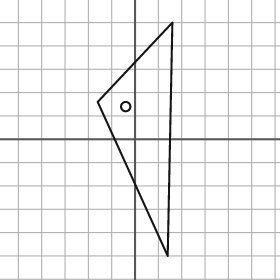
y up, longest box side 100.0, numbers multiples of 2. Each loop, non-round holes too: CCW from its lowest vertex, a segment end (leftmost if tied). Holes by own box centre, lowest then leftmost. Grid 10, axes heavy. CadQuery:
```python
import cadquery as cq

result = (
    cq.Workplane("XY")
    .moveTo(14.0, -50.0)
    .lineTo(16.0, 50.0)
    .lineTo(-16.0, 16.0)
    .close()
    .moveTo(-4.0, 14.0)
    .circle(2.0)
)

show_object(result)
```